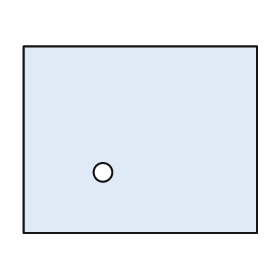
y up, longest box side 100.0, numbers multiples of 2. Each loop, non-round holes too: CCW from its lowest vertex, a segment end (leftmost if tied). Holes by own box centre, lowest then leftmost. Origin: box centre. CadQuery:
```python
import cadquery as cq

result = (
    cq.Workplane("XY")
    .moveTo(-50.0, -40.0)
    .lineTo(50.0, -40.0)
    .lineTo(50.0, 40.0)
    .lineTo(-50.0, 40.0)
    .close()
    .moveTo(-16.0, -14.0)
    .circle(4.0)
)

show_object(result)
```